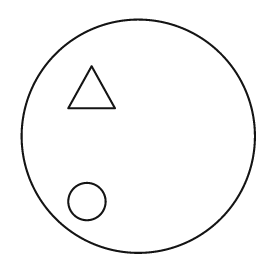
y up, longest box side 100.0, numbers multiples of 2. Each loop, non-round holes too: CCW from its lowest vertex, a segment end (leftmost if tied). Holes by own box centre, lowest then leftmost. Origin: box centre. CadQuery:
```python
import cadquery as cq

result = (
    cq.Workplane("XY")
    .moveTo(0.0, 0.0)
    .circle(50.0)
    .moveTo(-22.0, -28.0)
    .circle(8.0)
    .moveTo(-30.0, 12.0)
    .lineTo(-10.0, 12.0)
    .lineTo(-20.0, 30.0)
    .close()
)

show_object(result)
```